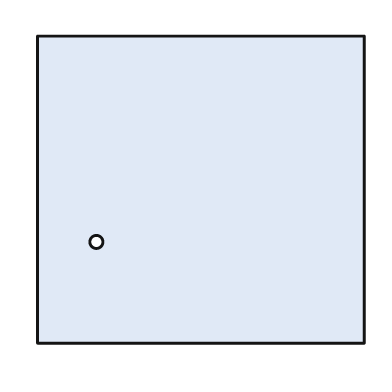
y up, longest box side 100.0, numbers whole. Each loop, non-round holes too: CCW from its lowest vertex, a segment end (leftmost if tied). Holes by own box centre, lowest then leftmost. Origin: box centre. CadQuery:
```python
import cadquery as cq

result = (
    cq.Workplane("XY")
    .moveTo(-50.0, -47.0)
    .lineTo(50.0, -47.0)
    .lineTo(50.0, 47.0)
    .lineTo(-50.0, 47.0)
    .close()
    .moveTo(-32.0, -16.0)
    .circle(2.0)
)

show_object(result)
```